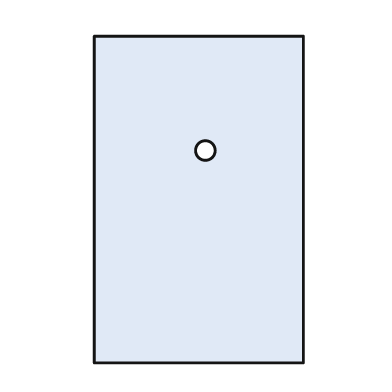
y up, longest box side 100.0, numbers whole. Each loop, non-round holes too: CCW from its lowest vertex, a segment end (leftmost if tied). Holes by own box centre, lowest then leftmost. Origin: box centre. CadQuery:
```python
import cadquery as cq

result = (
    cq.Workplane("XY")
    .moveTo(-32.0, -50.0)
    .lineTo(32.0, -50.0)
    .lineTo(32.0, 50.0)
    .lineTo(-32.0, 50.0)
    .close()
    .moveTo(2.0, 15.0)
    .circle(3.0)
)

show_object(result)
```